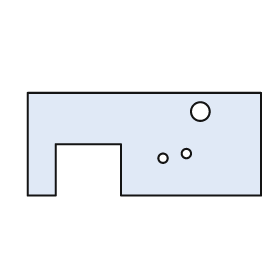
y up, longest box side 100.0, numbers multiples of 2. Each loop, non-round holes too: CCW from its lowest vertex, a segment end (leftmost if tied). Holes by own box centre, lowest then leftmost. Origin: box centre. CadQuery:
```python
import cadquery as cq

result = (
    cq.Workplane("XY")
    .moveTo(-50.0, -22.0)
    .lineTo(-38.0, -22.0)
    .lineTo(-38.0, 0.0)
    .lineTo(-10.0, 0.0)
    .lineTo(-10.0, -22.0)
    .lineTo(50.0, -22.0)
    .lineTo(50.0, 22.0)
    .lineTo(-50.0, 22.0)
    .close()
    .moveTo(8.0, -6.0)
    .circle(2.0)
    .moveTo(18.0, -4.0)
    .circle(2.0)
    .moveTo(24.0, 14.0)
    .circle(4.0)
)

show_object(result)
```